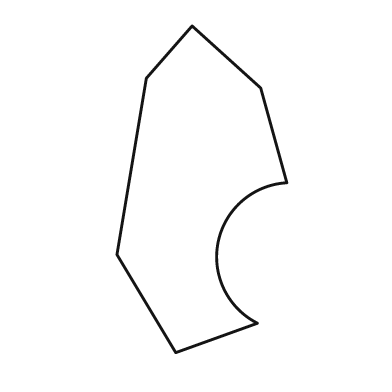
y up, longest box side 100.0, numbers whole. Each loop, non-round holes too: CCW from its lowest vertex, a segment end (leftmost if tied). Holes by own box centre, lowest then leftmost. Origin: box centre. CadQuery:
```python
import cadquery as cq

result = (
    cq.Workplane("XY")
    .moveTo(-8.0, -50.0)
    .lineTo(17.0, -41.0)
    .threePointArc((5.0, -16.0), (26.0, 2.0))
    .lineTo(18.0, 31.0)
    .lineTo(-3.0, 50.0)
    .lineTo(-17.0, 34.0)
    .lineTo(-26.0, -20.0)
    .close()
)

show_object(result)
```